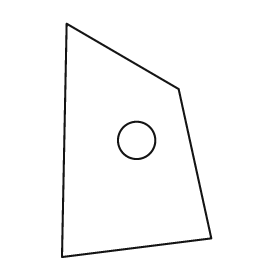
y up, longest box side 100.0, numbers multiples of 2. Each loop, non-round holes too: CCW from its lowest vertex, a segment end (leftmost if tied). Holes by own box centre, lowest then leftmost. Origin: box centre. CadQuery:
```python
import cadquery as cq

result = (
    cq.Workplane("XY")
    .moveTo(-32.0, -50.0)
    .lineTo(32.0, -42.0)
    .lineTo(18.0, 22.0)
    .lineTo(-30.0, 50.0)
    .close()
    .moveTo(0.0, 0.0)
    .circle(8.0)
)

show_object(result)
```